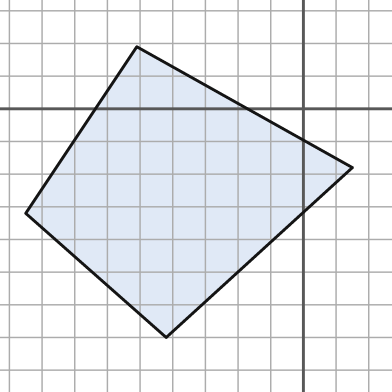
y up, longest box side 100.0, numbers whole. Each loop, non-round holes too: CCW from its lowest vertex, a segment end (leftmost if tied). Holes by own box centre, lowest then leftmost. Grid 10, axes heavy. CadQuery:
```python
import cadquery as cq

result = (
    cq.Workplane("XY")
    .moveTo(-42.0, -70.0)
    .lineTo(15.0, -18.0)
    .lineTo(-51.0, 19.0)
    .lineTo(-85.0, -32.0)
    .close()
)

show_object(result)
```